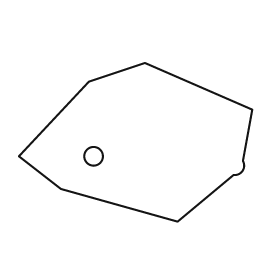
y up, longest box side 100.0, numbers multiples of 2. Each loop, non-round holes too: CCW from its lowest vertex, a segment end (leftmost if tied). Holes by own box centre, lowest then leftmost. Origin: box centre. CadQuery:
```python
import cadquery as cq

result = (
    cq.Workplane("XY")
    .moveTo(18.0, -34.0)
    .lineTo(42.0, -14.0)
    .threePointArc((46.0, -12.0), (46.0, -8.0))
    .lineTo(50.0, 14.0)
    .lineTo(4.0, 34.0)
    .lineTo(-20.0, 26.0)
    .lineTo(-50.0, -6.0)
    .lineTo(-32.0, -20.0)
    .close()
    .moveTo(-18.0, -6.0)
    .circle(4.0)
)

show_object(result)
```